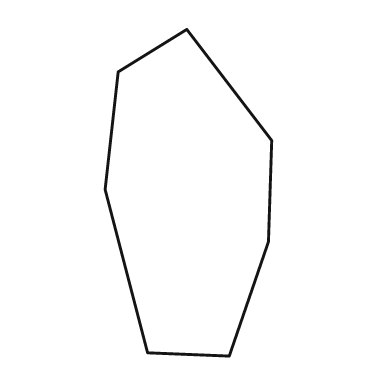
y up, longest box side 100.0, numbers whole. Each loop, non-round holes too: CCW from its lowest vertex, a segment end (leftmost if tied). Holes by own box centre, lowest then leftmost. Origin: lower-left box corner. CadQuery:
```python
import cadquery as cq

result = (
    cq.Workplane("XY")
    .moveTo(38.0, 0.0)
    .lineTo(50.0, 35.0)
    .lineTo(51.0, 66.0)
    .lineTo(25.0, 100.0)
    .lineTo(4.0, 87.0)
    .lineTo(0.0, 51.0)
    .lineTo(13.0, 1.0)
    .close()
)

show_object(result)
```